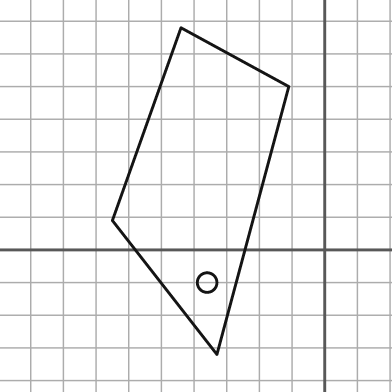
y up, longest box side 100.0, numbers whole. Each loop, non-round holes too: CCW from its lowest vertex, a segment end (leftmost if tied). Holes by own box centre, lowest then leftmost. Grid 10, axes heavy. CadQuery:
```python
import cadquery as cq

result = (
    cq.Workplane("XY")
    .moveTo(-33.0, -32.0)
    .lineTo(-11.0, 50.0)
    .lineTo(-44.0, 68.0)
    .lineTo(-65.0, 9.0)
    .close()
    .moveTo(-36.0, -10.0)
    .circle(3.0)
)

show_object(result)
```